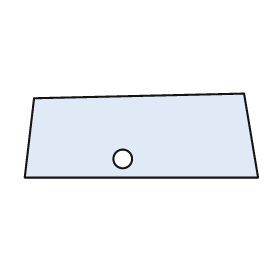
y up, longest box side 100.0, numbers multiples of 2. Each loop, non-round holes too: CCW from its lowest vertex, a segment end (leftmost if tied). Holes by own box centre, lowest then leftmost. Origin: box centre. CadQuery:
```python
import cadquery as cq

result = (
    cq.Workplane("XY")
    .moveTo(-50.0, -18.0)
    .lineTo(50.0, -18.0)
    .lineTo(44.0, 18.0)
    .lineTo(-46.0, 16.0)
    .close()
    .moveTo(-8.0, -10.0)
    .circle(4.0)
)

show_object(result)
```